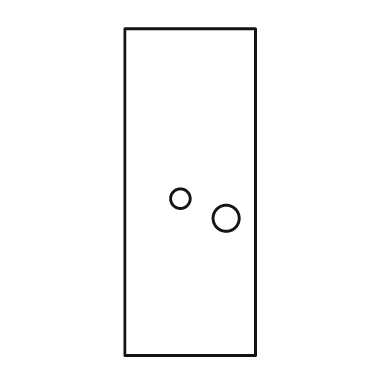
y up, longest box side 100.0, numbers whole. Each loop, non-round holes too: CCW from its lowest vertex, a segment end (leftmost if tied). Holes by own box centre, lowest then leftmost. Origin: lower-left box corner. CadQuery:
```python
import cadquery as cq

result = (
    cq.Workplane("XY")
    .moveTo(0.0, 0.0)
    .lineTo(40.0, 0.0)
    .lineTo(40.0, 100.0)
    .lineTo(0.0, 100.0)
    .close()
    .moveTo(31.0, 42.0)
    .circle(4.0)
    .moveTo(17.0, 48.0)
    .circle(3.0)
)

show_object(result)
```